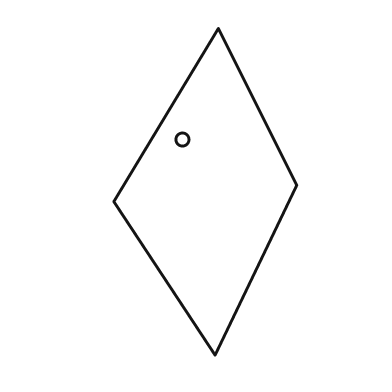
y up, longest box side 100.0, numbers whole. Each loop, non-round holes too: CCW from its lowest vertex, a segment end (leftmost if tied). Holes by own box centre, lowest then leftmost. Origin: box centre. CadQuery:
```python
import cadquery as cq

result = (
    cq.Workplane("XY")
    .moveTo(3.0, -50.0)
    .lineTo(28.0, 2.0)
    .lineTo(4.0, 50.0)
    .lineTo(-28.0, -3.0)
    .close()
    .moveTo(-7.0, 16.0)
    .circle(2.0)
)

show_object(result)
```